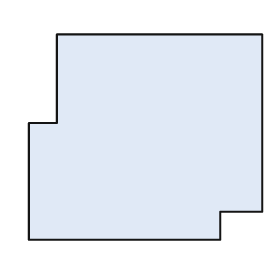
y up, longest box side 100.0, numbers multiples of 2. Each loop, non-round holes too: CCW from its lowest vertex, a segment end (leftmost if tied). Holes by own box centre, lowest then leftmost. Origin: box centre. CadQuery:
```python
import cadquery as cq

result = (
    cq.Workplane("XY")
    .moveTo(-50.0, -44.0)
    .lineTo(32.0, -44.0)
    .lineTo(32.0, -32.0)
    .lineTo(50.0, -32.0)
    .lineTo(50.0, 44.0)
    .lineTo(-38.0, 44.0)
    .lineTo(-38.0, 6.0)
    .lineTo(-50.0, 6.0)
    .close()
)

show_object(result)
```